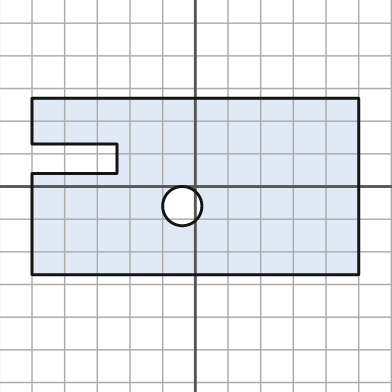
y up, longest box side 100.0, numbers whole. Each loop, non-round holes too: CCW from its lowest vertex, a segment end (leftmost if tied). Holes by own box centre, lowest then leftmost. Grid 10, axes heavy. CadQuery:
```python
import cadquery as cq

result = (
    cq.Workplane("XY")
    .moveTo(-50.0, -27.0)
    .lineTo(50.0, -27.0)
    .lineTo(50.0, 27.0)
    .lineTo(-50.0, 27.0)
    .lineTo(-50.0, 13.0)
    .lineTo(-24.0, 13.0)
    .lineTo(-24.0, 4.0)
    .lineTo(-50.0, 4.0)
    .close()
    .moveTo(-4.0, -6.0)
    .circle(6.0)
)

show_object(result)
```